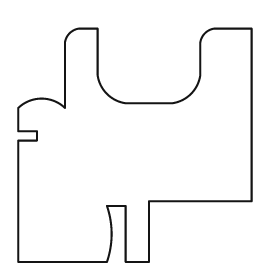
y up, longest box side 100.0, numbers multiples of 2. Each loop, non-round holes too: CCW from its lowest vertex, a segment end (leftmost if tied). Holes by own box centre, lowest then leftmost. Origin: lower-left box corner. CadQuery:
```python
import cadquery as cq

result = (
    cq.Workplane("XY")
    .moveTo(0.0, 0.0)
    .lineTo(38.0, 0.0)
    .threePointArc((40.0, 12.0), (38.0, 24.0))
    .lineTo(46.0, 24.0)
    .lineTo(46.0, 0.0)
    .lineTo(56.0, 0.0)
    .lineTo(56.0, 26.0)
    .lineTo(100.0, 26.0)
    .lineTo(100.0, 100.0)
    .lineTo(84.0, 100.0)
    .threePointArc((80.0, 98.0), (78.0, 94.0))
    .lineTo(78.0, 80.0)
    .threePointArc((74.0, 72.0), (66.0, 68.0))
    .lineTo(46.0, 68.0)
    .threePointArc((38.0, 72.0), (34.0, 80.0))
    .lineTo(34.0, 100.0)
    .lineTo(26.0, 100.0)
    .threePointArc((22.0, 98.0), (20.0, 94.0))
    .lineTo(20.0, 66.0)
    .threePointArc((10.0, 70.0), (0.0, 66.0))
    .lineTo(0.0, 56.0)
    .lineTo(8.0, 56.0)
    .lineTo(8.0, 52.0)
    .lineTo(0.0, 52.0)
    .close()
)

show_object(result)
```